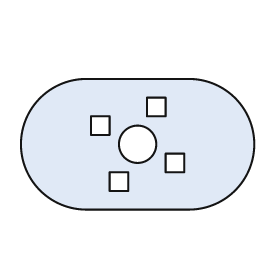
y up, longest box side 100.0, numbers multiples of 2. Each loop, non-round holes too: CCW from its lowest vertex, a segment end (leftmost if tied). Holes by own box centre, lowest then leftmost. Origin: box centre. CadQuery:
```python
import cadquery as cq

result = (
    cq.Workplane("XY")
    .moveTo(-22.0, -28.0)
    .lineTo(22.0, -28.0)
    .threePointArc((50.0, 0.0), (22.0, 28.0))
    .lineTo(-22.0, 28.0)
    .threePointArc((-50.0, 0.0), (-22.0, -28.0))
    .close()
    .moveTo(-12.0, -20.0)
    .lineTo(-4.0, -20.0)
    .lineTo(-4.0, -12.0)
    .lineTo(-12.0, -12.0)
    .close()
    .moveTo(12.0, -12.0)
    .lineTo(20.0, -12.0)
    .lineTo(20.0, -4.0)
    .lineTo(12.0, -4.0)
    .close()
    .moveTo(0.0, 0.0)
    .circle(8.0)
    .moveTo(-20.0, 4.0)
    .lineTo(-12.0, 4.0)
    .lineTo(-12.0, 12.0)
    .lineTo(-20.0, 12.0)
    .close()
    .moveTo(4.0, 12.0)
    .lineTo(12.0, 12.0)
    .lineTo(12.0, 20.0)
    .lineTo(4.0, 20.0)
    .close()
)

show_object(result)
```